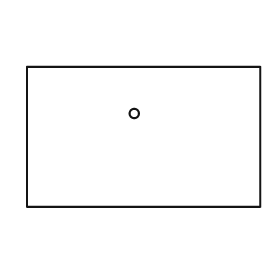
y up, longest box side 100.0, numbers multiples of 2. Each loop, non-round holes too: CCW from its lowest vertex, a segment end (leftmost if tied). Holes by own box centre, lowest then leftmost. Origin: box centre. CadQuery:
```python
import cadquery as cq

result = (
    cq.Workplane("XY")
    .moveTo(-50.0, -30.0)
    .lineTo(50.0, -30.0)
    .lineTo(50.0, 30.0)
    .lineTo(-50.0, 30.0)
    .close()
    .moveTo(-4.0, 10.0)
    .circle(2.0)
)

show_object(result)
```